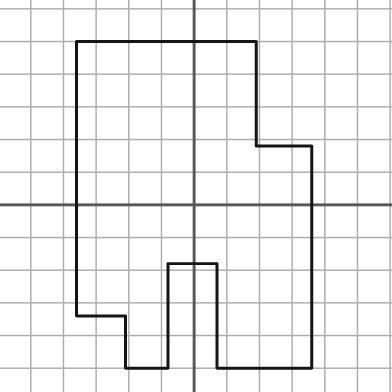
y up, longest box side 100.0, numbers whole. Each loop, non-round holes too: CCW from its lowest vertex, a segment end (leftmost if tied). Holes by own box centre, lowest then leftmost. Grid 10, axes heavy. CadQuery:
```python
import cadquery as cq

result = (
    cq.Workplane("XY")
    .moveTo(-21.0, -50.0)
    .lineTo(-8.0, -50.0)
    .lineTo(-8.0, -18.0)
    .lineTo(7.0, -18.0)
    .lineTo(7.0, -50.0)
    .lineTo(36.0, -50.0)
    .lineTo(36.0, 18.0)
    .lineTo(19.0, 18.0)
    .lineTo(19.0, 50.0)
    .lineTo(-36.0, 50.0)
    .lineTo(-36.0, -34.0)
    .lineTo(-21.0, -34.0)
    .close()
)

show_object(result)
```